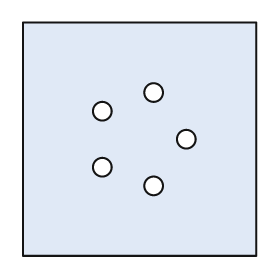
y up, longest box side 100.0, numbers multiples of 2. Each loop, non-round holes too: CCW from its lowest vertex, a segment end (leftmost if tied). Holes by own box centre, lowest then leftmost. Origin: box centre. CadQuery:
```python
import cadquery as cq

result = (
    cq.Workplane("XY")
    .moveTo(-50.0, -50.0)
    .lineTo(50.0, -50.0)
    .lineTo(50.0, 50.0)
    .lineTo(-50.0, 50.0)
    .close()
    .moveTo(6.0, -20.0)
    .circle(4.0)
    .moveTo(-16.0, -12.0)
    .circle(4.0)
    .moveTo(20.0, 0.0)
    .circle(4.0)
    .moveTo(-16.0, 12.0)
    .circle(4.0)
    .moveTo(6.0, 20.0)
    .circle(4.0)
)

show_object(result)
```